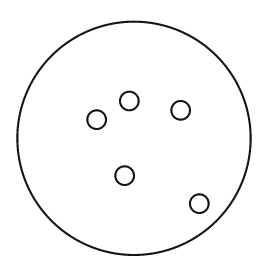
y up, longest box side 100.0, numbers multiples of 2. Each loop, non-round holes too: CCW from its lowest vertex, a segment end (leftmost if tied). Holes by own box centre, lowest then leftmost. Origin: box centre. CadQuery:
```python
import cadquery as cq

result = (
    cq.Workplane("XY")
    .moveTo(0.0, 0.0)
    .circle(50.0)
    .moveTo(28.0, -28.0)
    .circle(4.0)
    .moveTo(-4.0, -16.0)
    .circle(4.0)
    .moveTo(-16.0, 8.0)
    .circle(4.0)
    .moveTo(20.0, 12.0)
    .circle(4.0)
    .moveTo(-2.0, 16.0)
    .circle(4.0)
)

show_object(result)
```